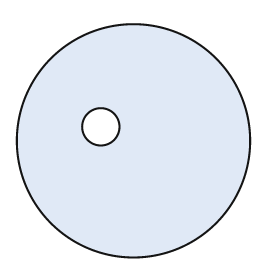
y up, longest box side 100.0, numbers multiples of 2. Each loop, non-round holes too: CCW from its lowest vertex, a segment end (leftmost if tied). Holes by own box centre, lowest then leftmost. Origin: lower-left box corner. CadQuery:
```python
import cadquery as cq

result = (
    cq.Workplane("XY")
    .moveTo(50.0, 50.0)
    .circle(50.0)
    .moveTo(36.0, 56.0)
    .circle(8.0)
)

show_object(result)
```